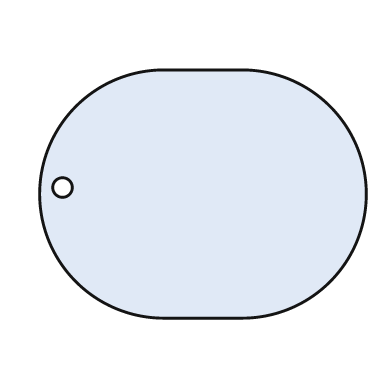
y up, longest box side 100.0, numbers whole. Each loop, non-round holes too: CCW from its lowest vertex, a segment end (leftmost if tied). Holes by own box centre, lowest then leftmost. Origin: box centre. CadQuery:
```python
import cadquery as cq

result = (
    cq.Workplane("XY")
    .moveTo(-12.0, -38.0)
    .lineTo(12.0, -38.0)
    .threePointArc((50.0, 0.0), (12.0, 38.0))
    .lineTo(-12.0, 38.0)
    .threePointArc((-50.0, 0.0), (-12.0, -38.0))
    .close()
    .moveTo(-43.0, 2.0)
    .circle(3.0)
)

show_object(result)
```